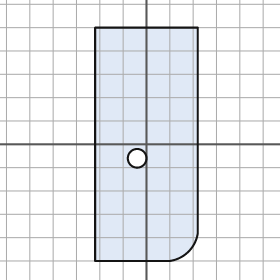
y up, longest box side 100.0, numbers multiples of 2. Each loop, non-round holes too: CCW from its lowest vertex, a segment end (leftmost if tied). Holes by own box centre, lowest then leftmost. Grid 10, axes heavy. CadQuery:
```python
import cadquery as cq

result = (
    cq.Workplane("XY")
    .moveTo(-22.0, -50.0)
    .lineTo(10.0, -50.0)
    .threePointArc((18.0, -46.0), (22.0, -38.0))
    .lineTo(22.0, 50.0)
    .lineTo(-22.0, 50.0)
    .close()
    .moveTo(-4.0, -6.0)
    .circle(4.0)
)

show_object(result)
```